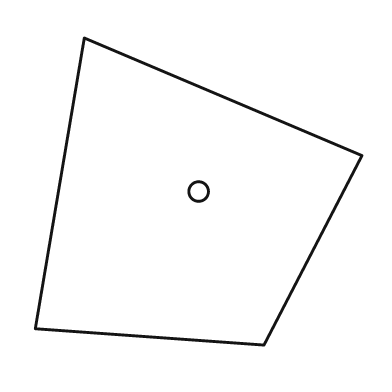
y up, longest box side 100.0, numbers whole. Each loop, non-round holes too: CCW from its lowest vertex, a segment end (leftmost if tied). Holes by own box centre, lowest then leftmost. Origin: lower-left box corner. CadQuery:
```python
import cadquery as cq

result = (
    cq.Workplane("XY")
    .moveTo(70.0, 0.0)
    .lineTo(100.0, 58.0)
    .lineTo(15.0, 94.0)
    .lineTo(0.0, 5.0)
    .close()
    .moveTo(50.0, 47.0)
    .circle(3.0)
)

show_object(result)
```